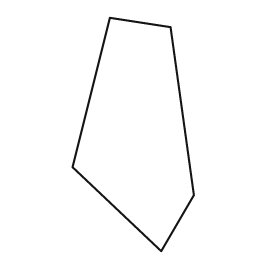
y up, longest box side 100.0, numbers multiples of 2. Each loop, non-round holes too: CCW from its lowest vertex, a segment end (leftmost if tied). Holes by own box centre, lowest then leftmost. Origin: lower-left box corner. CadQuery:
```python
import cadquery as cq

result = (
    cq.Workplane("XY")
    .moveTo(38.0, 0.0)
    .lineTo(52.0, 24.0)
    .lineTo(42.0, 96.0)
    .lineTo(16.0, 100.0)
    .lineTo(0.0, 36.0)
    .close()
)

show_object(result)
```